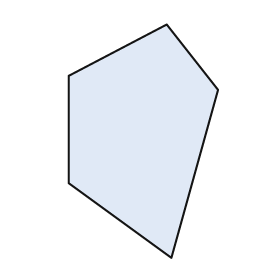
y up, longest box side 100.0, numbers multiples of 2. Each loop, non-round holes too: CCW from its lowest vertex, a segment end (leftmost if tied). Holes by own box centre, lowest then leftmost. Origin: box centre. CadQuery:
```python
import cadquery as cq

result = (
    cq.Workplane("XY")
    .moveTo(12.0, -50.0)
    .lineTo(32.0, 22.0)
    .lineTo(10.0, 50.0)
    .lineTo(-32.0, 28.0)
    .lineTo(-32.0, -18.0)
    .close()
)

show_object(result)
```